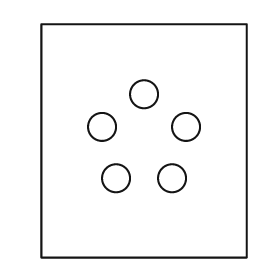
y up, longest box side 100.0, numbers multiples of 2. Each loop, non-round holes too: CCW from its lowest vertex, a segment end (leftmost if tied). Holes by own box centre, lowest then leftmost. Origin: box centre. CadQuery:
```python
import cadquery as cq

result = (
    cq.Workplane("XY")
    .moveTo(-44.0, -50.0)
    .lineTo(44.0, -50.0)
    .lineTo(44.0, 50.0)
    .lineTo(-44.0, 50.0)
    .close()
    .moveTo(-12.0, -16.0)
    .circle(6.0)
    .moveTo(12.0, -16.0)
    .circle(6.0)
    .moveTo(-18.0, 6.0)
    .circle(6.0)
    .moveTo(18.0, 6.0)
    .circle(6.0)
    .moveTo(0.0, 20.0)
    .circle(6.0)
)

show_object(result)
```